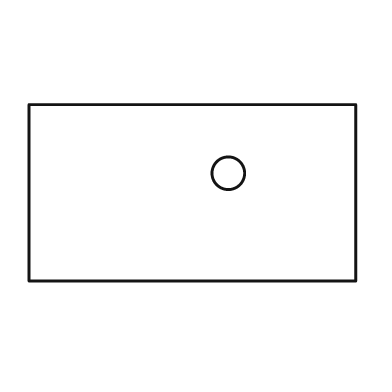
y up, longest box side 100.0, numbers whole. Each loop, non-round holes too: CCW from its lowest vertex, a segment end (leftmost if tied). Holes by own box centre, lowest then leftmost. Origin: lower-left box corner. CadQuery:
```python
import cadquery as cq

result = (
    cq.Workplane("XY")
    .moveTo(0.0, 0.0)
    .lineTo(100.0, 0.0)
    .lineTo(100.0, 54.0)
    .lineTo(0.0, 54.0)
    .close()
    .moveTo(61.0, 33.0)
    .circle(5.0)
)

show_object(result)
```